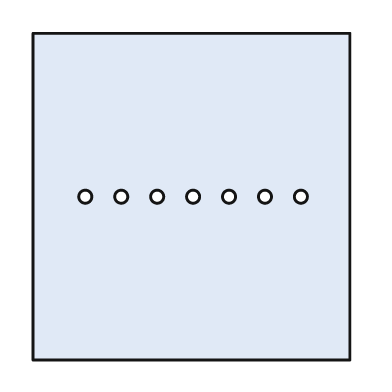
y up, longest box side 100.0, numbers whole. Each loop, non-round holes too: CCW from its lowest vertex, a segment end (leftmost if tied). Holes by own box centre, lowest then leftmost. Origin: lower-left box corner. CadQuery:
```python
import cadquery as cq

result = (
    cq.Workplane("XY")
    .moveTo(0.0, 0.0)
    .lineTo(97.0, 0.0)
    .lineTo(97.0, 100.0)
    .lineTo(0.0, 100.0)
    .close()
    .moveTo(16.0, 50.0)
    .circle(2.0)
    .moveTo(27.0, 50.0)
    .circle(2.0)
    .moveTo(38.0, 50.0)
    .circle(2.0)
    .moveTo(49.0, 50.0)
    .circle(2.0)
    .moveTo(60.0, 50.0)
    .circle(2.0)
    .moveTo(71.0, 50.0)
    .circle(2.0)
    .moveTo(82.0, 50.0)
    .circle(2.0)
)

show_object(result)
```